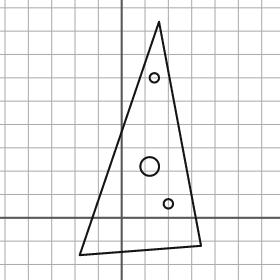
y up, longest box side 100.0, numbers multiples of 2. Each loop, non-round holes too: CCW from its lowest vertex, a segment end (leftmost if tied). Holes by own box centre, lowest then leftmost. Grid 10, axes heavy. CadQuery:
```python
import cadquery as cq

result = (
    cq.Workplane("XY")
    .moveTo(-18.0, -16.0)
    .lineTo(34.0, -12.0)
    .lineTo(16.0, 84.0)
    .close()
    .moveTo(20.0, 6.0)
    .circle(2.0)
    .moveTo(12.0, 22.0)
    .circle(4.0)
    .moveTo(14.0, 60.0)
    .circle(2.0)
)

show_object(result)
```